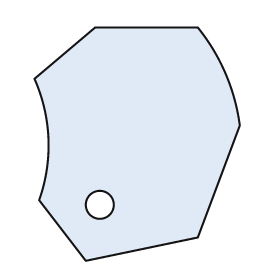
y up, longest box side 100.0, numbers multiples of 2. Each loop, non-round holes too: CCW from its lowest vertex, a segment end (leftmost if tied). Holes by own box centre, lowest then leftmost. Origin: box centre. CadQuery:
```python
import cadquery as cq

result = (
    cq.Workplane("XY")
    .moveTo(-22.0, -50.0)
    .lineTo(26.0, -40.0)
    .lineTo(44.0, 8.0)
    .threePointArc((38.0, 30.0), (26.0, 50.0))
    .lineTo(-18.0, 50.0)
    .lineTo(-44.0, 28.0)
    .threePointArc((-38.0, 2.0), (-42.0, -24.0))
    .close()
    .moveTo(-16.0, -26.0)
    .circle(6.0)
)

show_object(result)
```